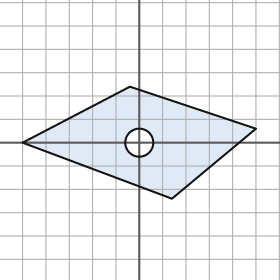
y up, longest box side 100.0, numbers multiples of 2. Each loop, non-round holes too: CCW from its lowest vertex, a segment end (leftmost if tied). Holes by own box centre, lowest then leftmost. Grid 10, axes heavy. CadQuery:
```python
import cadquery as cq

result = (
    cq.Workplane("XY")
    .moveTo(14.0, -24.0)
    .lineTo(50.0, 6.0)
    .lineTo(-4.0, 24.0)
    .lineTo(-50.0, 0.0)
    .close()
    .moveTo(0.0, 0.0)
    .circle(6.0)
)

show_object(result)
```